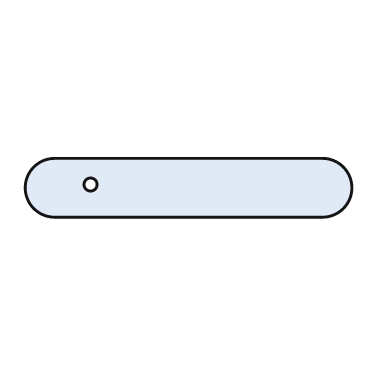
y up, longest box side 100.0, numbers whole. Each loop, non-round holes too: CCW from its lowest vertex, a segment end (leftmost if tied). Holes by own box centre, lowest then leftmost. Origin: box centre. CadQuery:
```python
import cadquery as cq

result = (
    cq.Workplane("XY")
    .moveTo(-41.0, -9.0)
    .lineTo(41.0, -9.0)
    .threePointArc((50.0, 0.0), (41.0, 9.0))
    .lineTo(-41.0, 9.0)
    .threePointArc((-50.0, 0.0), (-41.0, -9.0))
    .close()
    .moveTo(-30.0, 1.0)
    .circle(2.0)
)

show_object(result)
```